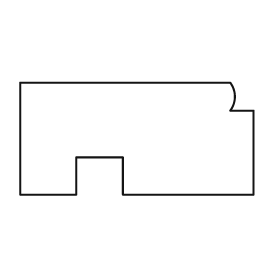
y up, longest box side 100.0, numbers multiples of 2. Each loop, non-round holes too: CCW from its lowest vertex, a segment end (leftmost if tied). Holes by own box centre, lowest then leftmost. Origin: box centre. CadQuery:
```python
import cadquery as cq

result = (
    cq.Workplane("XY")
    .moveTo(-50.0, -24.0)
    .lineTo(-26.0, -24.0)
    .lineTo(-26.0, -8.0)
    .lineTo(-6.0, -8.0)
    .lineTo(-6.0, -24.0)
    .lineTo(50.0, -24.0)
    .lineTo(50.0, 12.0)
    .lineTo(40.0, 12.0)
    .threePointArc((42.0, 18.0), (40.0, 24.0))
    .lineTo(-50.0, 24.0)
    .close()
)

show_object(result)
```